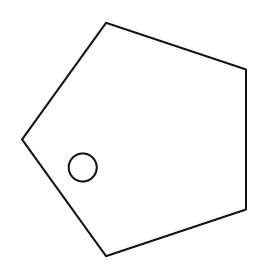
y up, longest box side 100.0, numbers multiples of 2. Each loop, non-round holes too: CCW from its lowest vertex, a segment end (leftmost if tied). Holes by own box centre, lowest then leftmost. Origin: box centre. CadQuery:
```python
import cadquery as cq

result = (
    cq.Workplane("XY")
    .moveTo(-12.0, -50.0)
    .lineTo(48.0, -30.0)
    .lineTo(48.0, 30.0)
    .lineTo(-12.0, 50.0)
    .lineTo(-48.0, 0.0)
    .close()
    .moveTo(-22.0, -12.0)
    .circle(6.0)
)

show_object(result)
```